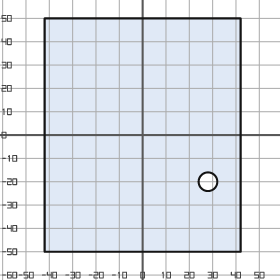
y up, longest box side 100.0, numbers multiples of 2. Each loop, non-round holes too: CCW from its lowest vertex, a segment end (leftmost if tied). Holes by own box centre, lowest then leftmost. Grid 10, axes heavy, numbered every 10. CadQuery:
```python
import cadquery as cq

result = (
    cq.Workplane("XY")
    .moveTo(-42.0, -50.0)
    .lineTo(42.0, -50.0)
    .lineTo(42.0, 50.0)
    .lineTo(-42.0, 50.0)
    .close()
    .moveTo(28.0, -20.0)
    .circle(4.0)
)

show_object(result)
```